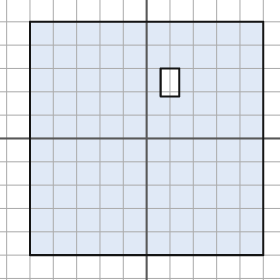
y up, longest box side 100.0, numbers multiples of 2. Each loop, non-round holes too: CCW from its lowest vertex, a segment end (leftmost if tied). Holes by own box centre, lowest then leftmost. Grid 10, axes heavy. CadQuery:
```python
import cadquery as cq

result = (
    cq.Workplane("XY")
    .moveTo(-50.0, -50.0)
    .lineTo(50.0, -50.0)
    .lineTo(50.0, 50.0)
    .lineTo(-50.0, 50.0)
    .close()
    .moveTo(6.0, 18.0)
    .lineTo(14.0, 18.0)
    .lineTo(14.0, 30.0)
    .lineTo(6.0, 30.0)
    .close()
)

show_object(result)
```